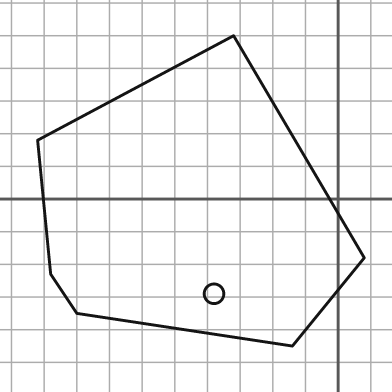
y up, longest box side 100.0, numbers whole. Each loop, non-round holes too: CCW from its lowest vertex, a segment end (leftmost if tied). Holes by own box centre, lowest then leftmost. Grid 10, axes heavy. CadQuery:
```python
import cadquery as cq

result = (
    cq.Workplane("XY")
    .moveTo(-14.0, -45.0)
    .lineTo(8.0, -18.0)
    .lineTo(-32.0, 50.0)
    .lineTo(-92.0, 18.0)
    .lineTo(-88.0, -23.0)
    .lineTo(-80.0, -35.0)
    .close()
    .moveTo(-38.0, -29.0)
    .circle(3.0)
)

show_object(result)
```